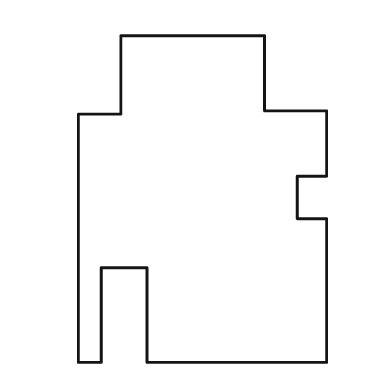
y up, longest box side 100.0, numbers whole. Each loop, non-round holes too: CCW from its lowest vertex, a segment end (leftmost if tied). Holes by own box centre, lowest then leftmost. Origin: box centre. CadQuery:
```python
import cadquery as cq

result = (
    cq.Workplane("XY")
    .moveTo(-38.0, -50.0)
    .lineTo(-31.0, -50.0)
    .lineTo(-31.0, -21.0)
    .lineTo(-17.0, -21.0)
    .lineTo(-17.0, -50.0)
    .lineTo(38.0, -50.0)
    .lineTo(38.0, -6.0)
    .lineTo(29.0, -6.0)
    .lineTo(29.0, 7.0)
    .lineTo(38.0, 7.0)
    .lineTo(38.0, 27.0)
    .lineTo(19.0, 27.0)
    .lineTo(19.0, 50.0)
    .lineTo(-25.0, 50.0)
    .lineTo(-25.0, 26.0)
    .lineTo(-38.0, 26.0)
    .close()
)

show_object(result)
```